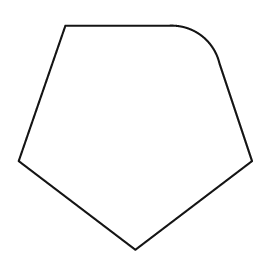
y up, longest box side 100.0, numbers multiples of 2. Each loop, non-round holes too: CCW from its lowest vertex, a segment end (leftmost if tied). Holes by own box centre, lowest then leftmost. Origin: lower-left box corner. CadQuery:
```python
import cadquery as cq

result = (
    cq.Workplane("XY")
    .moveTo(50.0, 0.0)
    .lineTo(100.0, 38.0)
    .lineTo(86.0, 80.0)
    .threePointArc((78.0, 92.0), (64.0, 96.0))
    .lineTo(20.0, 96.0)
    .lineTo(0.0, 38.0)
    .close()
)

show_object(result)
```